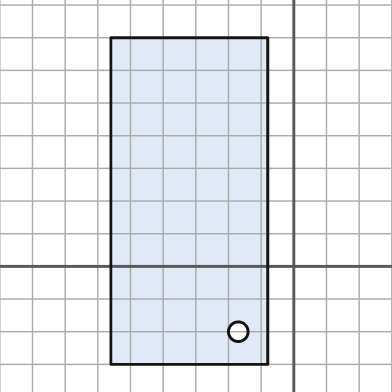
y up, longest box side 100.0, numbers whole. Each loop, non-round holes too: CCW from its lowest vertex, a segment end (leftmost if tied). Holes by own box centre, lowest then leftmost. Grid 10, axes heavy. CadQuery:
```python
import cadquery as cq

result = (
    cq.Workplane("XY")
    .moveTo(-56.0, -30.0)
    .lineTo(-8.0, -30.0)
    .lineTo(-8.0, 70.0)
    .lineTo(-56.0, 70.0)
    .close()
    .moveTo(-17.0, -20.0)
    .circle(3.0)
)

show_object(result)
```